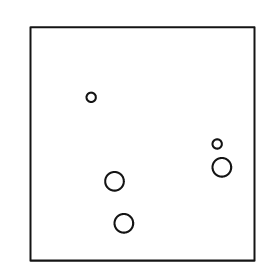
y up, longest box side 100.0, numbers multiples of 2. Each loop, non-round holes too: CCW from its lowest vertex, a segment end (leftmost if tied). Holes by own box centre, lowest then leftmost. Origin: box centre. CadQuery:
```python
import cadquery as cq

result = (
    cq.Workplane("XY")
    .moveTo(-48.0, -50.0)
    .lineTo(48.0, -50.0)
    .lineTo(48.0, 50.0)
    .lineTo(-48.0, 50.0)
    .close()
    .moveTo(-8.0, -34.0)
    .circle(4.0)
    .moveTo(-12.0, -16.0)
    .circle(4.0)
    .moveTo(34.0, -10.0)
    .circle(4.0)
    .moveTo(32.0, 0.0)
    .circle(2.0)
    .moveTo(-22.0, 20.0)
    .circle(2.0)
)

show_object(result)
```